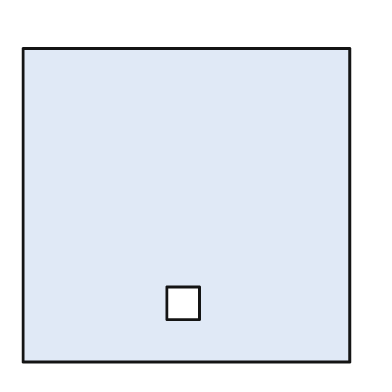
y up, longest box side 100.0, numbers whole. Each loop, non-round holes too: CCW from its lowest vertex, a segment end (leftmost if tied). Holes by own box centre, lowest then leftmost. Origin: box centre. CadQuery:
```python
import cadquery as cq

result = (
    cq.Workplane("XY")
    .moveTo(-50.0, -48.0)
    .lineTo(50.0, -48.0)
    .lineTo(50.0, 48.0)
    .lineTo(-50.0, 48.0)
    .close()
    .moveTo(-6.0, -35.0)
    .lineTo(4.0, -35.0)
    .lineTo(4.0, -25.0)
    .lineTo(-6.0, -25.0)
    .close()
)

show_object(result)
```